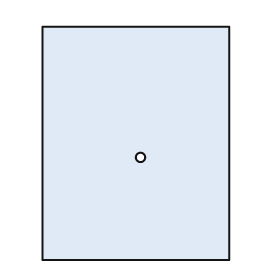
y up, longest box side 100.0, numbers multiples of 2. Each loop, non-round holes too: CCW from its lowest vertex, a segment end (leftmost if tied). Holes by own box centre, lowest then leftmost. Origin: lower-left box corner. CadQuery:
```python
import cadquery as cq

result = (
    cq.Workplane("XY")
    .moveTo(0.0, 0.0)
    .lineTo(80.0, 0.0)
    .lineTo(80.0, 100.0)
    .lineTo(0.0, 100.0)
    .close()
    .moveTo(42.0, 44.0)
    .circle(2.0)
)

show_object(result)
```